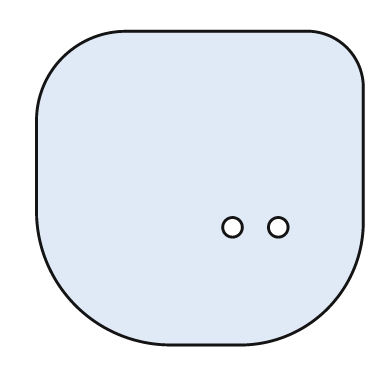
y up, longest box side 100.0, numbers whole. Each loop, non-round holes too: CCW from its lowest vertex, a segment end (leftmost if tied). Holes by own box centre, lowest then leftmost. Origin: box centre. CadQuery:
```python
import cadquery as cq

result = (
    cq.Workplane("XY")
    .moveTo(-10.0, -48.0)
    .lineTo(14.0, -48.0)
    .threePointArc((39.0, -37.0), (50.0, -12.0))
    .lineTo(50.0, 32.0)
    .threePointArc((45.0, 43.0), (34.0, 48.0))
    .lineTo(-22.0, 48.0)
    .threePointArc((-42.0, 40.0), (-50.0, 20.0))
    .lineTo(-50.0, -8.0)
    .threePointArc((-38.0, -36.0), (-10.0, -48.0))
    .close()
    .moveTo(10.0, -12.0)
    .circle(3.0)
    .moveTo(24.0, -12.0)
    .circle(3.0)
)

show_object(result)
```